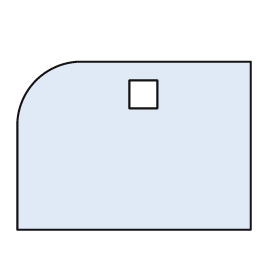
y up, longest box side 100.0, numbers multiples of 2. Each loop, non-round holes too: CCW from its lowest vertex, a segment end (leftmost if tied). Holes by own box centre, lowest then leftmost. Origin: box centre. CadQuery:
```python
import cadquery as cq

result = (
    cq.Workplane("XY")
    .moveTo(-50.0, -36.0)
    .lineTo(50.0, -36.0)
    .lineTo(50.0, 36.0)
    .lineTo(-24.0, 36.0)
    .threePointArc((-42.0, 28.0), (-50.0, 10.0))
    .close()
    .moveTo(-2.0, 16.0)
    .lineTo(10.0, 16.0)
    .lineTo(10.0, 28.0)
    .lineTo(-2.0, 28.0)
    .close()
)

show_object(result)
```